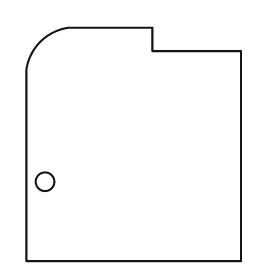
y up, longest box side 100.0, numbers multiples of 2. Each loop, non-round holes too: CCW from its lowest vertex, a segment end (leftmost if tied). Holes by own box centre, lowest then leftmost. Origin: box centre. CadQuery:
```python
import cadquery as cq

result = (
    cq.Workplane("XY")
    .moveTo(-46.0, -50.0)
    .lineTo(46.0, -50.0)
    .lineTo(46.0, 40.0)
    .lineTo(8.0, 40.0)
    .lineTo(8.0, 50.0)
    .lineTo(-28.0, 50.0)
    .threePointArc((-40.0, 44.0), (-46.0, 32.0))
    .close()
    .moveTo(-38.0, -16.0)
    .circle(4.0)
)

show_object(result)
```